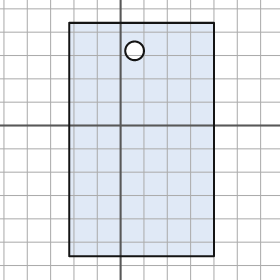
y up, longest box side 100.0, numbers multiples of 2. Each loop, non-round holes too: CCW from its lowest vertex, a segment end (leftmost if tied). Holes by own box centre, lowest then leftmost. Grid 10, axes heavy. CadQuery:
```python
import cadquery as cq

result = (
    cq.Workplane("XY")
    .moveTo(-22.0, -56.0)
    .lineTo(40.0, -56.0)
    .lineTo(40.0, 44.0)
    .lineTo(-22.0, 44.0)
    .close()
    .moveTo(6.0, 32.0)
    .circle(4.0)
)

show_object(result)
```